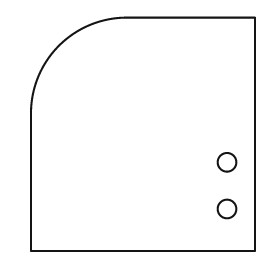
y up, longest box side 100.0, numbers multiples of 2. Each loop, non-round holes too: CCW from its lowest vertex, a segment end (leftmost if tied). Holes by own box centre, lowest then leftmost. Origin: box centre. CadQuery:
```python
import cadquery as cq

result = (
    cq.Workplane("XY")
    .moveTo(-48.0, -50.0)
    .lineTo(48.0, -50.0)
    .lineTo(48.0, 50.0)
    .lineTo(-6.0, 50.0)
    .threePointArc((-36.0, 38.0), (-48.0, 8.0))
    .close()
    .moveTo(36.0, -32.0)
    .circle(4.0)
    .moveTo(36.0, -12.0)
    .circle(4.0)
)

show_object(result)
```